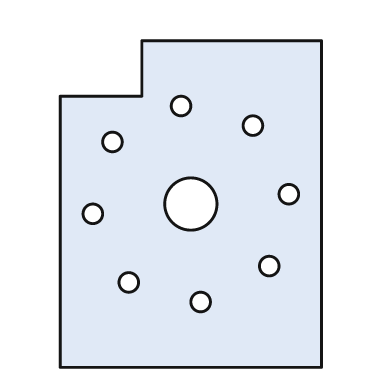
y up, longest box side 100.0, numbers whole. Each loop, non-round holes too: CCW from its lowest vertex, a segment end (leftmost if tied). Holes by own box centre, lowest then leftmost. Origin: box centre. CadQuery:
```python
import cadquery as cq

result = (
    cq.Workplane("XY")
    .moveTo(-40.0, -50.0)
    .lineTo(40.0, -50.0)
    .lineTo(40.0, 50.0)
    .lineTo(-15.0, 50.0)
    .lineTo(-15.0, 33.0)
    .lineTo(-40.0, 33.0)
    .close()
    .moveTo(3.0, -30.0)
    .circle(3.0)
    .moveTo(-19.0, -24.0)
    .circle(3.0)
    .moveTo(24.0, -19.0)
    .circle(3.0)
    .moveTo(-30.0, -3.0)
    .circle(3.0)
    .moveTo(0.0, 0.0)
    .circle(8.0)
    .moveTo(30.0, 3.0)
    .circle(3.0)
    .moveTo(-24.0, 19.0)
    .circle(3.0)
    .moveTo(19.0, 24.0)
    .circle(3.0)
    .moveTo(-3.0, 30.0)
    .circle(3.0)
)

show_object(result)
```